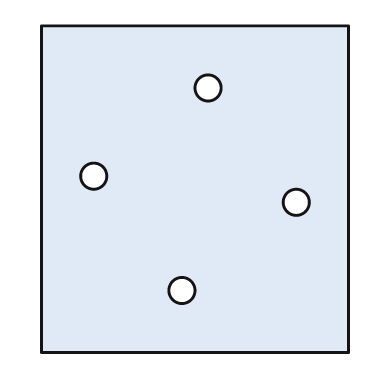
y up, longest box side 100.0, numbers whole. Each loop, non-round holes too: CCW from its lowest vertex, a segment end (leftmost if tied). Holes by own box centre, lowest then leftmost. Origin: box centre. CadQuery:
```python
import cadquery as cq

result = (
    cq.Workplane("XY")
    .moveTo(-47.0, -50.0)
    .lineTo(47.0, -50.0)
    .lineTo(47.0, 50.0)
    .lineTo(-47.0, 50.0)
    .close()
    .moveTo(-4.0, -31.0)
    .circle(4.0)
    .moveTo(31.0, -4.0)
    .circle(4.0)
    .moveTo(-31.0, 4.0)
    .circle(4.0)
    .moveTo(4.0, 31.0)
    .circle(4.0)
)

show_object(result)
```